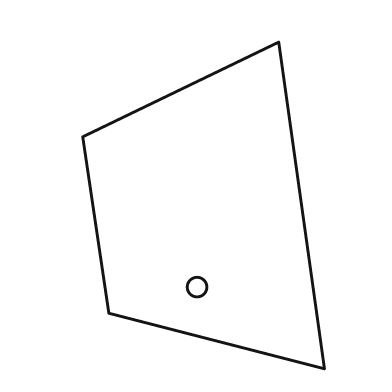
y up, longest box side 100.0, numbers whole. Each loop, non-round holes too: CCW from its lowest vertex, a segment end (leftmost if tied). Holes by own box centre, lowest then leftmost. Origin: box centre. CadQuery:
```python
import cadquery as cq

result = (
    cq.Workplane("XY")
    .moveTo(37.0, -50.0)
    .lineTo(23.0, 50.0)
    .lineTo(-37.0, 21.0)
    .lineTo(-29.0, -33.0)
    .close()
    .moveTo(-2.0, -25.0)
    .circle(3.0)
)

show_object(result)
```